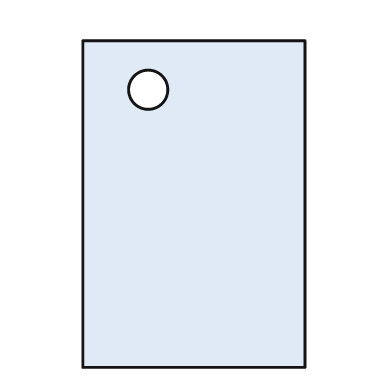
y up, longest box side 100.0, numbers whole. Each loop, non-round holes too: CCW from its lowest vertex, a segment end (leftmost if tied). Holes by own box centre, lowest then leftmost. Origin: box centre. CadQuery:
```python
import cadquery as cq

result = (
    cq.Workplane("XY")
    .moveTo(-34.0, -50.0)
    .lineTo(34.0, -50.0)
    .lineTo(34.0, 50.0)
    .lineTo(-34.0, 50.0)
    .close()
    .moveTo(-14.0, 35.0)
    .circle(6.0)
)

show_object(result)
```